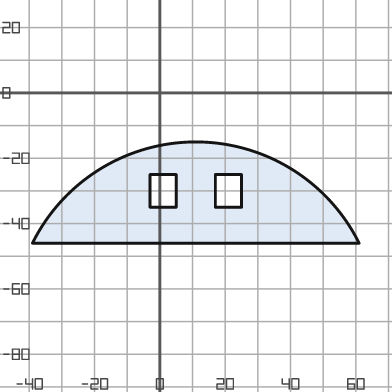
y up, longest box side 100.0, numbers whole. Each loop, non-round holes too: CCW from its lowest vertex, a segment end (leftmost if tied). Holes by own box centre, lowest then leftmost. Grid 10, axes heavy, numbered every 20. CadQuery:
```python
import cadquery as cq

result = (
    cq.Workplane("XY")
    .moveTo(-39.0, -46.0)
    .lineTo(61.0, -46.0)
    .threePointArc((11.0, -15.0), (-39.0, -46.0))
    .close()
    .moveTo(-3.0, -35.0)
    .lineTo(5.0, -35.0)
    .lineTo(5.0, -25.0)
    .lineTo(-3.0, -25.0)
    .close()
    .moveTo(17.0, -35.0)
    .lineTo(25.0, -35.0)
    .lineTo(25.0, -25.0)
    .lineTo(17.0, -25.0)
    .close()
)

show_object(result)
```